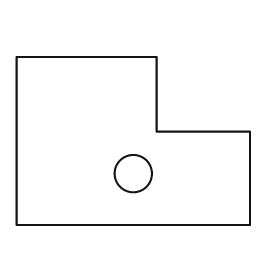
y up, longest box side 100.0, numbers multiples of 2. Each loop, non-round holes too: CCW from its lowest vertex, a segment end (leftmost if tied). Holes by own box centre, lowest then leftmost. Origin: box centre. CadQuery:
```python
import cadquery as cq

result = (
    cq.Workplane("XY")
    .moveTo(-50.0, -36.0)
    .lineTo(50.0, -36.0)
    .lineTo(50.0, 4.0)
    .lineTo(10.0, 4.0)
    .lineTo(10.0, 36.0)
    .lineTo(-50.0, 36.0)
    .close()
    .moveTo(0.0, -14.0)
    .circle(8.0)
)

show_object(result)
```